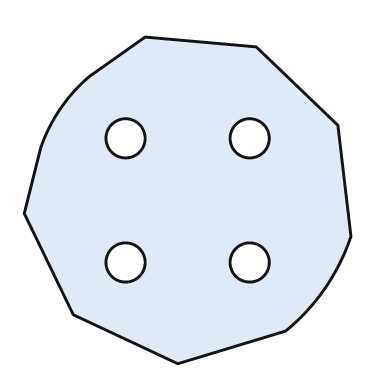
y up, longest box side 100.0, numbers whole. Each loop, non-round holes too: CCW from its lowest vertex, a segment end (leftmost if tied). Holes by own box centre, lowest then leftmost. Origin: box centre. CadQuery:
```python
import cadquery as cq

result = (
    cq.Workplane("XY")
    .moveTo(-3.0, -50.0)
    .lineTo(30.0, -40.0)
    .threePointArc((42.0, -27.0), (50.0, -11.0))
    .lineTo(46.0, 23.0)
    .lineTo(21.0, 47.0)
    .lineTo(-13.0, 50.0)
    .lineTo(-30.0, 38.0)
    .threePointArc((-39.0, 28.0), (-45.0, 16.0))
    .lineTo(-50.0, -4.0)
    .lineTo(-35.0, -35.0)
    .close()
    .moveTo(-19.0, -19.0)
    .circle(6.0)
    .moveTo(19.0, -19.0)
    .circle(6.0)
    .moveTo(-19.0, 19.0)
    .circle(6.0)
    .moveTo(19.0, 19.0)
    .circle(6.0)
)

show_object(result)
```